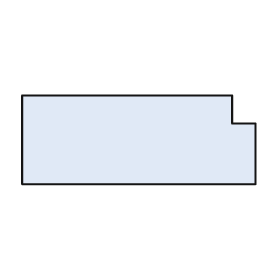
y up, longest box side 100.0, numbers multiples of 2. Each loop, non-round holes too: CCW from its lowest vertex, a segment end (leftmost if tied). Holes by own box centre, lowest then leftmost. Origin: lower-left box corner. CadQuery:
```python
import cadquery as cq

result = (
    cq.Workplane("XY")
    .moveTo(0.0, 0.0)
    .lineTo(100.0, 0.0)
    .lineTo(100.0, 26.0)
    .lineTo(90.0, 26.0)
    .lineTo(90.0, 38.0)
    .lineTo(0.0, 38.0)
    .close()
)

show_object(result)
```